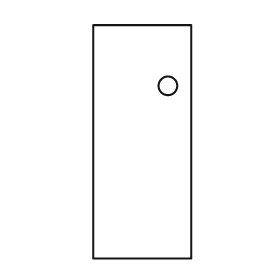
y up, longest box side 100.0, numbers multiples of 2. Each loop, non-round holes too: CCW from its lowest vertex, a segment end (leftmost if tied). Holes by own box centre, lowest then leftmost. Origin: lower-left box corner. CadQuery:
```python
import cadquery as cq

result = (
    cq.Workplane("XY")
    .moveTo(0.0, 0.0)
    .lineTo(42.0, 0.0)
    .lineTo(42.0, 100.0)
    .lineTo(0.0, 100.0)
    .close()
    .moveTo(32.0, 74.0)
    .circle(4.0)
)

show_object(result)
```